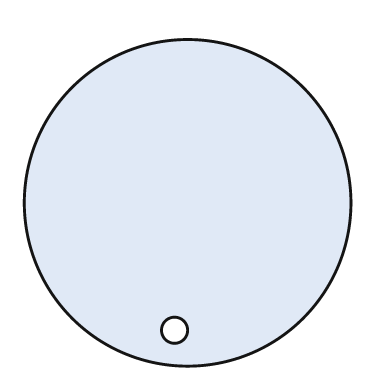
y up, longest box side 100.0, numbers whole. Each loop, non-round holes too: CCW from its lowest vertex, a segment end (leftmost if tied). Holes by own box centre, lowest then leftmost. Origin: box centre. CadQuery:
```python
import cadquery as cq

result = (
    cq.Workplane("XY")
    .moveTo(0.0, 0.0)
    .circle(50.0)
    .moveTo(-4.0, -39.0)
    .circle(4.0)
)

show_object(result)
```